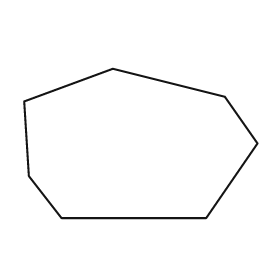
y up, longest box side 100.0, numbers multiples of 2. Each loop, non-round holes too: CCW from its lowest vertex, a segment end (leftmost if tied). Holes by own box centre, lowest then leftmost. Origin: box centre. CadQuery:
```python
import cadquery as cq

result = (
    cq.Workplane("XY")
    .moveTo(-34.0, -32.0)
    .lineTo(28.0, -32.0)
    .lineTo(50.0, 0.0)
    .lineTo(36.0, 20.0)
    .lineTo(-12.0, 32.0)
    .lineTo(-50.0, 18.0)
    .lineTo(-48.0, -14.0)
    .close()
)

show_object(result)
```